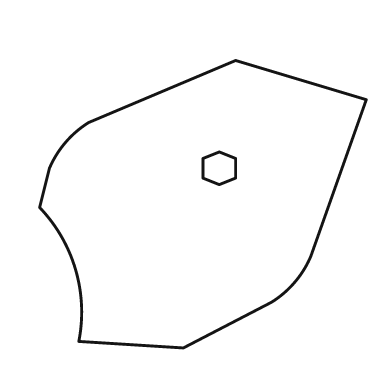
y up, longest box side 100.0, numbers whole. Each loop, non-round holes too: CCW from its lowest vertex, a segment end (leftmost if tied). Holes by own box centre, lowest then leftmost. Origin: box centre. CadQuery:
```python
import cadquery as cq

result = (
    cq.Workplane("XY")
    .moveTo(-6.0, -44.0)
    .lineTo(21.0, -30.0)
    .threePointArc((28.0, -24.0), (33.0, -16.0))
    .lineTo(50.0, 32.0)
    .lineTo(10.0, 44.0)
    .lineTo(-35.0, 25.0)
    .threePointArc((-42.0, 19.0), (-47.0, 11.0))
    .lineTo(-50.0, -1.0)
    .threePointArc((-39.0, -20.0), (-38.0, -42.0))
    .close()
    .moveTo(5.0, 6.0)
    .lineTo(10.0, 8.0)
    .lineTo(10.0, 14.0)
    .lineTo(5.0, 16.0)
    .lineTo(0.0, 14.0)
    .lineTo(0.0, 8.0)
    .close()
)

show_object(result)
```